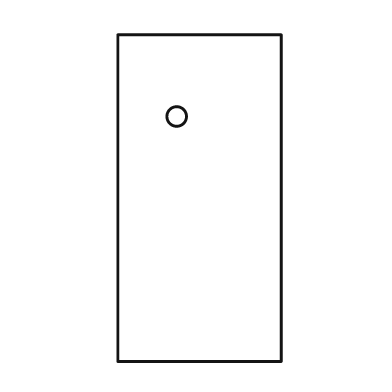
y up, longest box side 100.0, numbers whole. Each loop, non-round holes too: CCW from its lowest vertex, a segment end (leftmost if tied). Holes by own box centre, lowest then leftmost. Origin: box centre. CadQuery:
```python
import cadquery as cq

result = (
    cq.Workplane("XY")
    .moveTo(-25.0, -50.0)
    .lineTo(25.0, -50.0)
    .lineTo(25.0, 50.0)
    .lineTo(-25.0, 50.0)
    .close()
    .moveTo(-7.0, 25.0)
    .circle(3.0)
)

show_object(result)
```